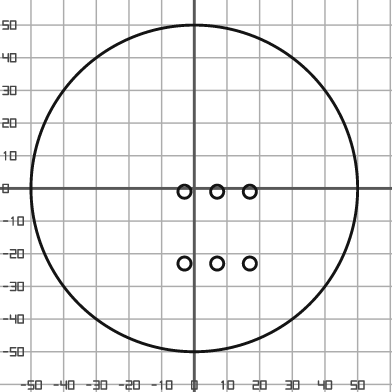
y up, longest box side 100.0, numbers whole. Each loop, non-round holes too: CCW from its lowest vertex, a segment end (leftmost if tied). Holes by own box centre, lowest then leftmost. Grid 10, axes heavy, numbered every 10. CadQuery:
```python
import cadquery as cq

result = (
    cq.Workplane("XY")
    .moveTo(0.0, 0.0)
    .circle(50.0)
    .moveTo(-3.0, -23.0)
    .circle(2.0)
    .moveTo(7.0, -23.0)
    .circle(2.0)
    .moveTo(17.0, -23.0)
    .circle(2.0)
    .moveTo(-3.0, -1.0)
    .circle(2.0)
    .moveTo(7.0, -1.0)
    .circle(2.0)
    .moveTo(17.0, -1.0)
    .circle(2.0)
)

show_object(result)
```